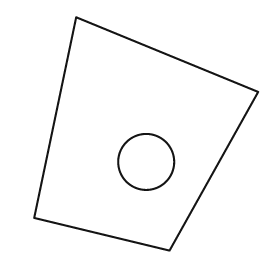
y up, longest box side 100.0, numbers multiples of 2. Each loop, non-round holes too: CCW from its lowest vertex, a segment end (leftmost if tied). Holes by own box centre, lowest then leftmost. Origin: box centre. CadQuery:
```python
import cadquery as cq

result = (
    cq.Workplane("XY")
    .moveTo(10.0, -50.0)
    .lineTo(48.0, 18.0)
    .lineTo(-30.0, 50.0)
    .lineTo(-48.0, -36.0)
    .close()
    .moveTo(0.0, -12.0)
    .circle(12.0)
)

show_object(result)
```